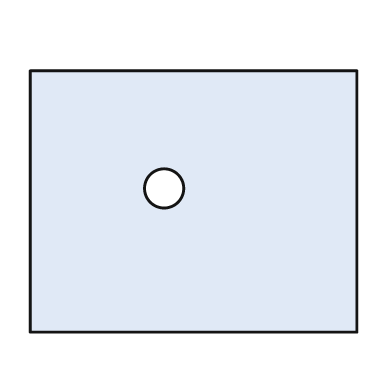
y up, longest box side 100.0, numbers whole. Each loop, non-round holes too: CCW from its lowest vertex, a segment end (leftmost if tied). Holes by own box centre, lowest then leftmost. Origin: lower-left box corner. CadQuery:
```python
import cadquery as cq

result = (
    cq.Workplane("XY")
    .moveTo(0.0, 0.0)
    .lineTo(100.0, 0.0)
    .lineTo(100.0, 80.0)
    .lineTo(0.0, 80.0)
    .close()
    .moveTo(41.0, 44.0)
    .circle(6.0)
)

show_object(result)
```